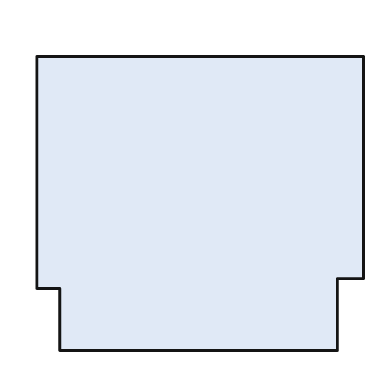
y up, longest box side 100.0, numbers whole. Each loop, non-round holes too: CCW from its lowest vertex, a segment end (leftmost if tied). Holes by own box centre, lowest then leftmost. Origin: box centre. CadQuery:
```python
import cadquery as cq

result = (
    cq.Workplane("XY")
    .moveTo(-43.0, -45.0)
    .lineTo(42.0, -45.0)
    .lineTo(42.0, -23.0)
    .lineTo(50.0, -23.0)
    .lineTo(50.0, 45.0)
    .lineTo(-50.0, 45.0)
    .lineTo(-50.0, -26.0)
    .lineTo(-43.0, -26.0)
    .close()
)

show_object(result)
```